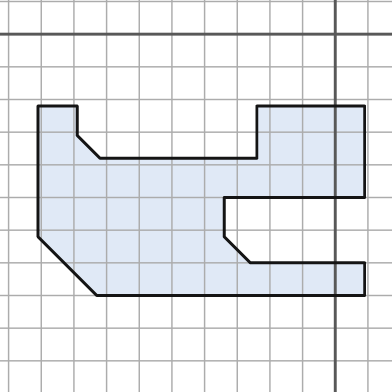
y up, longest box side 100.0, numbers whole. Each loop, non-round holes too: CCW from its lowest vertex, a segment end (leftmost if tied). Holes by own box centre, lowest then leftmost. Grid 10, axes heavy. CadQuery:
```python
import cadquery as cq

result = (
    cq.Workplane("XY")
    .moveTo(-73.0, -80.0)
    .lineTo(9.0, -80.0)
    .lineTo(9.0, -70.0)
    .lineTo(-26.0, -70.0)
    .lineTo(-34.0, -62.0)
    .lineTo(-34.0, -50.0)
    .lineTo(9.0, -50.0)
    .lineTo(9.0, -22.0)
    .lineTo(-24.0, -22.0)
    .lineTo(-24.0, -38.0)
    .lineTo(-72.0, -38.0)
    .lineTo(-79.0, -31.0)
    .lineTo(-79.0, -22.0)
    .lineTo(-91.0, -22.0)
    .lineTo(-91.0, -62.0)
    .close()
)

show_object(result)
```